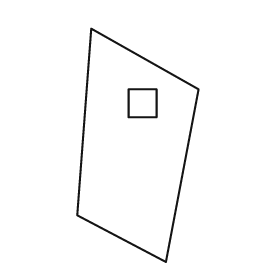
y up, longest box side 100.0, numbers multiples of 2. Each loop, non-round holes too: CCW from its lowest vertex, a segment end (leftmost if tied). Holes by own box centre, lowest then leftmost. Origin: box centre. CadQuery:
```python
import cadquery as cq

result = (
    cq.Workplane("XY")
    .moveTo(12.0, -50.0)
    .lineTo(26.0, 24.0)
    .lineTo(-20.0, 50.0)
    .lineTo(-26.0, -30.0)
    .close()
    .moveTo(-4.0, 12.0)
    .lineTo(8.0, 12.0)
    .lineTo(8.0, 24.0)
    .lineTo(-4.0, 24.0)
    .close()
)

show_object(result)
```